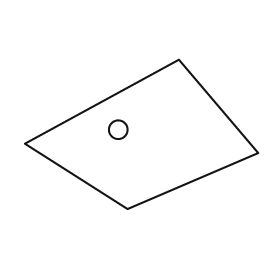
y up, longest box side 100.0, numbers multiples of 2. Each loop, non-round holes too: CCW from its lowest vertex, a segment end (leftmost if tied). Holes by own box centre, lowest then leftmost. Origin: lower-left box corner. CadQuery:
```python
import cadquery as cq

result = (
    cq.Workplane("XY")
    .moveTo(44.0, 0.0)
    .lineTo(100.0, 24.0)
    .lineTo(66.0, 64.0)
    .lineTo(0.0, 28.0)
    .close()
    .moveTo(40.0, 34.0)
    .circle(4.0)
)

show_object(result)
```